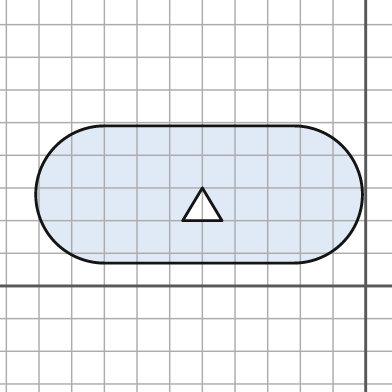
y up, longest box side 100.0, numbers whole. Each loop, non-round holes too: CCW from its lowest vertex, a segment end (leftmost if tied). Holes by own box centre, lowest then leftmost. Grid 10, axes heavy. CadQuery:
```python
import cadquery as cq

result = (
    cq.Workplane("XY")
    .moveTo(-80.0, 7.0)
    .lineTo(-22.0, 7.0)
    .threePointArc((-1.0, 28.0), (-22.0, 49.0))
    .lineTo(-80.0, 49.0)
    .threePointArc((-101.0, 28.0), (-80.0, 7.0))
    .close()
    .moveTo(-56.0, 20.0)
    .lineTo(-44.0, 20.0)
    .lineTo(-50.0, 30.0)
    .close()
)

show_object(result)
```